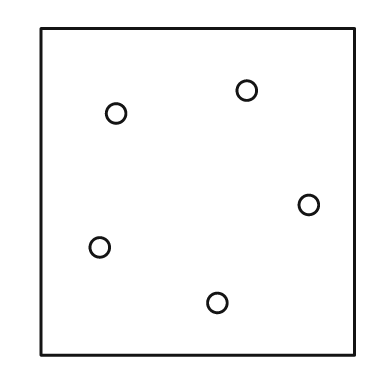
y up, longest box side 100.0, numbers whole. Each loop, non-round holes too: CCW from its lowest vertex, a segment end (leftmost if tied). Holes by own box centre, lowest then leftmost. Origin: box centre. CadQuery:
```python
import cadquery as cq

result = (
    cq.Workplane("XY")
    .moveTo(-48.0, -50.0)
    .lineTo(48.0, -50.0)
    .lineTo(48.0, 50.0)
    .lineTo(-48.0, 50.0)
    .close()
    .moveTo(6.0, -34.0)
    .circle(3.0)
    .moveTo(-30.0, -17.0)
    .circle(3.0)
    .moveTo(34.0, -4.0)
    .circle(3.0)
    .moveTo(-25.0, 24.0)
    .circle(3.0)
    .moveTo(15.0, 31.0)
    .circle(3.0)
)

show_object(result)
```